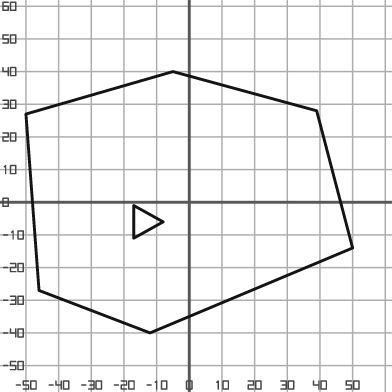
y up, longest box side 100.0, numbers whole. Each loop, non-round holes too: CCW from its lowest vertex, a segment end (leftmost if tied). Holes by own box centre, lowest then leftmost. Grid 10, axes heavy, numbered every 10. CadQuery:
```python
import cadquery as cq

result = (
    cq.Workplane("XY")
    .moveTo(-12.0, -40.0)
    .lineTo(50.0, -14.0)
    .lineTo(39.0, 28.0)
    .lineTo(-5.0, 40.0)
    .lineTo(-50.0, 27.0)
    .lineTo(-46.0, -27.0)
    .close()
    .moveTo(-17.0, -11.0)
    .lineTo(-8.0, -6.0)
    .lineTo(-17.0, -1.0)
    .close()
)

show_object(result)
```